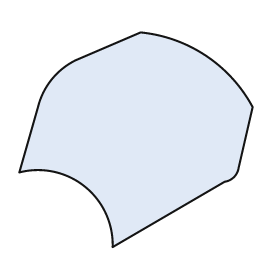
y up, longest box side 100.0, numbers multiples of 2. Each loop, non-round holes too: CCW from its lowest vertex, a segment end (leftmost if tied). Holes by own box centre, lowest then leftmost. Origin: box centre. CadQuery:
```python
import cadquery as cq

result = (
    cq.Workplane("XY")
    .moveTo(-10.0, -46.0)
    .lineTo(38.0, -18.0)
    .threePointArc((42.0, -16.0), (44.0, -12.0))
    .lineTo(50.0, 14.0)
    .threePointArc((30.0, 36.0), (2.0, 46.0))
    .lineTo(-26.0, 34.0)
    .threePointArc((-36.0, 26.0), (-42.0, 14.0))
    .lineTo(-50.0, -14.0)
    .threePointArc((-22.0, -20.0), (-10.0, -46.0))
    .close()
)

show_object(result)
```